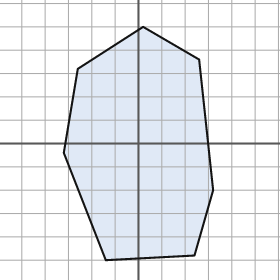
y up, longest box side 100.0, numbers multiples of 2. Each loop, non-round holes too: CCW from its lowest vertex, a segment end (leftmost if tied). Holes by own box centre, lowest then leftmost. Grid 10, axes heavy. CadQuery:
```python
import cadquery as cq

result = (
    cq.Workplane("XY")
    .moveTo(-14.0, -50.0)
    .lineTo(24.0, -48.0)
    .lineTo(32.0, -20.0)
    .lineTo(26.0, 36.0)
    .lineTo(2.0, 50.0)
    .lineTo(-26.0, 32.0)
    .lineTo(-32.0, -4.0)
    .close()
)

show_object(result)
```